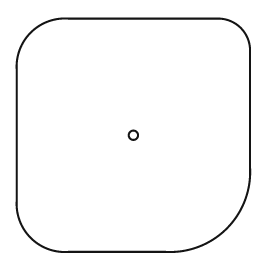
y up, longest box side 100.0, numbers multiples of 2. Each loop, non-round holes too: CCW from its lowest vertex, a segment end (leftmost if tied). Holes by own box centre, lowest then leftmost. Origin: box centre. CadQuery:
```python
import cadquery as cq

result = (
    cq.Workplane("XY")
    .moveTo(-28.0, -50.0)
    .lineTo(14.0, -50.0)
    .threePointArc((40.0, -40.0), (50.0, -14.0))
    .lineTo(50.0, 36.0)
    .threePointArc((46.0, 46.0), (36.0, 50.0))
    .lineTo(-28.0, 50.0)
    .threePointArc((-44.0, 44.0), (-50.0, 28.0))
    .lineTo(-50.0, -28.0)
    .threePointArc((-44.0, -44.0), (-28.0, -50.0))
    .close()
    .moveTo(0.0, 0.0)
    .circle(2.0)
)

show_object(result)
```